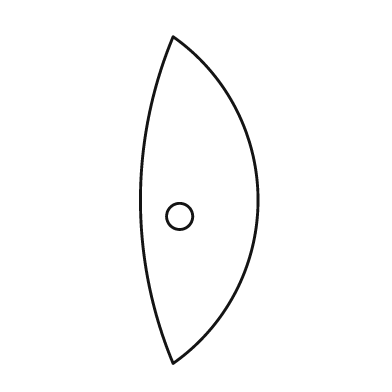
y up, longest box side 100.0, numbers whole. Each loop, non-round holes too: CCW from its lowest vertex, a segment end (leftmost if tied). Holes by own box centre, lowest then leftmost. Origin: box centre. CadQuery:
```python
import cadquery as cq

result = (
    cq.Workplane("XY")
    .moveTo(-8.0, -50.0)
    .threePointArc((18.0, 0.0), (-8.0, 50.0))
    .threePointArc((-18.0, 0.0), (-8.0, -50.0))
    .close()
    .moveTo(-6.0, -5.0)
    .circle(4.0)
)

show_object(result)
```